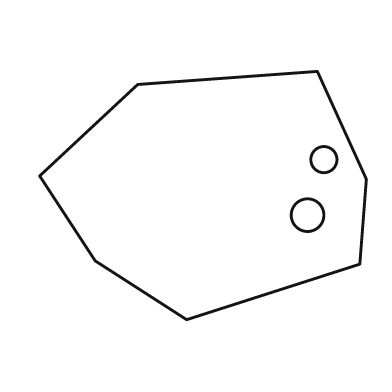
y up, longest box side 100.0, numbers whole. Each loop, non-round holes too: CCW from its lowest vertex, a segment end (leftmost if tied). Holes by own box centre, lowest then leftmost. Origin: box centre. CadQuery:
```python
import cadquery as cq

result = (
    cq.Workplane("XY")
    .moveTo(-5.0, -38.0)
    .lineTo(48.0, -21.0)
    .lineTo(50.0, 5.0)
    .lineTo(35.0, 38.0)
    .lineTo(-20.0, 34.0)
    .lineTo(-50.0, 6.0)
    .lineTo(-33.0, -20.0)
    .close()
    .moveTo(32.0, -6.0)
    .circle(5.0)
    .moveTo(37.0, 11.0)
    .circle(4.0)
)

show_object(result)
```